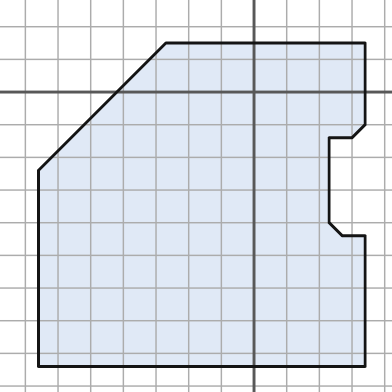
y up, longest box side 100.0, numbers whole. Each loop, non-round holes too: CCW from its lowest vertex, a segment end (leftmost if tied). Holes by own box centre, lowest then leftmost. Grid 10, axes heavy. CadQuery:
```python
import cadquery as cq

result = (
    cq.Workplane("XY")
    .moveTo(-66.0, -84.0)
    .lineTo(34.0, -84.0)
    .lineTo(34.0, -44.0)
    .lineTo(27.0, -44.0)
    .lineTo(23.0, -40.0)
    .lineTo(23.0, -14.0)
    .lineTo(30.0, -14.0)
    .lineTo(34.0, -10.0)
    .lineTo(34.0, 15.0)
    .lineTo(-27.0, 15.0)
    .lineTo(-66.0, -24.0)
    .close()
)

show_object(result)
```